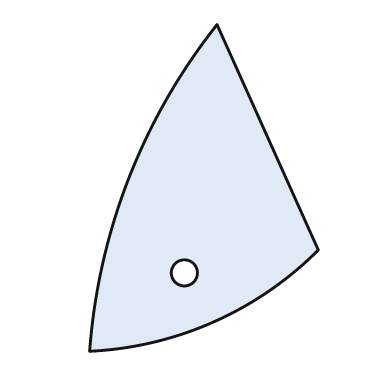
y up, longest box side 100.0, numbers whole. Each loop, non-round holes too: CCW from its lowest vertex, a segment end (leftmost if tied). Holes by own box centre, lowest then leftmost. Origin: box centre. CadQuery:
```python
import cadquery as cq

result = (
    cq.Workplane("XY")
    .moveTo(-35.0, -50.0)
    .threePointArc((3.0, -41.0), (35.0, -19.0))
    .lineTo(4.0, 50.0)
    .threePointArc((-23.0, 3.0), (-35.0, -50.0))
    .close()
    .moveTo(-6.0, -26.0)
    .circle(4.0)
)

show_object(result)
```